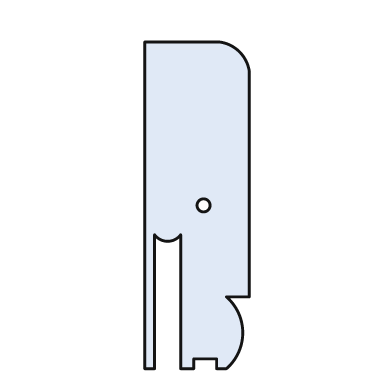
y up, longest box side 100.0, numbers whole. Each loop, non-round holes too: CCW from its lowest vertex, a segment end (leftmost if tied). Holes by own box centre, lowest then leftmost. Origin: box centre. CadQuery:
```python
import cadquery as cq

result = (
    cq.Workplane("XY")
    .moveTo(-16.0, -50.0)
    .lineTo(-13.0, -50.0)
    .lineTo(-13.0, -9.0)
    .threePointArc((-9.0, -11.0), (-5.0, -9.0))
    .lineTo(-5.0, -50.0)
    .lineTo(-1.0, -50.0)
    .lineTo(-1.0, -47.0)
    .lineTo(6.0, -47.0)
    .lineTo(6.0, -50.0)
    .lineTo(9.0, -50.0)
    .threePointArc((14.0, -39.0), (9.0, -28.0))
    .lineTo(16.0, -28.0)
    .lineTo(16.0, 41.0)
    .threePointArc((13.0, 47.0), (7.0, 50.0))
    .lineTo(-16.0, 50.0)
    .close()
    .moveTo(2.0, 0.0)
    .circle(2.0)
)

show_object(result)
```